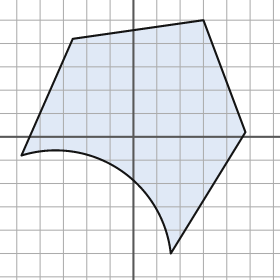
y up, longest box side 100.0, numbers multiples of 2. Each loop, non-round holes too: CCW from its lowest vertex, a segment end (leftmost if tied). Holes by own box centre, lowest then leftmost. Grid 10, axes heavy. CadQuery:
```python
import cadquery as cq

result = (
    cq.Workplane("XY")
    .moveTo(16.0, -50.0)
    .lineTo(48.0, 2.0)
    .lineTo(30.0, 50.0)
    .lineTo(-26.0, 42.0)
    .lineTo(-48.0, -8.0)
    .threePointArc((-6.0, -14.0), (16.0, -50.0))
    .close()
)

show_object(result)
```